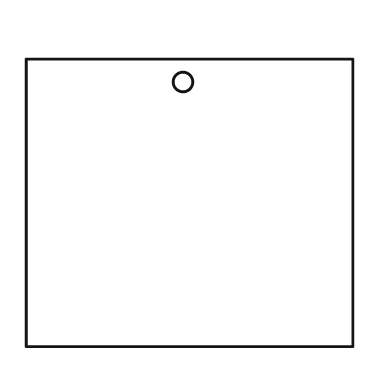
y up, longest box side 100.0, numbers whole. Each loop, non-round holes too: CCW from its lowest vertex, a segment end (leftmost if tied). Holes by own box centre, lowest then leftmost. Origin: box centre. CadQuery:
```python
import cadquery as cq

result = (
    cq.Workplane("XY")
    .moveTo(-50.0, -44.0)
    .lineTo(50.0, -44.0)
    .lineTo(50.0, 44.0)
    .lineTo(-50.0, 44.0)
    .close()
    .moveTo(-2.0, 37.0)
    .circle(3.0)
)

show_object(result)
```